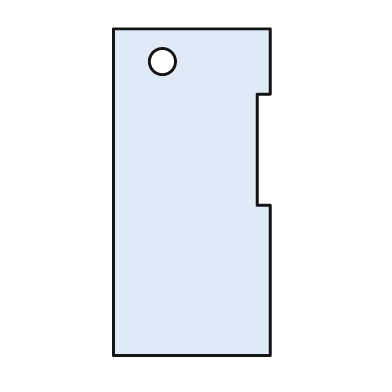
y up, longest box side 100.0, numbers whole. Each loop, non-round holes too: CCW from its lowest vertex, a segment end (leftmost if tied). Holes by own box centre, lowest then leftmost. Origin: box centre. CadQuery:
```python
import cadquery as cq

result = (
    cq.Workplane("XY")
    .moveTo(-24.0, -50.0)
    .lineTo(24.0, -50.0)
    .lineTo(24.0, -4.0)
    .lineTo(20.0, -4.0)
    .lineTo(20.0, 30.0)
    .lineTo(24.0, 30.0)
    .lineTo(24.0, 50.0)
    .lineTo(-24.0, 50.0)
    .close()
    .moveTo(-9.0, 40.0)
    .circle(4.0)
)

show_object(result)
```